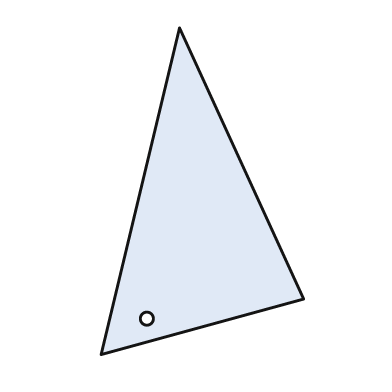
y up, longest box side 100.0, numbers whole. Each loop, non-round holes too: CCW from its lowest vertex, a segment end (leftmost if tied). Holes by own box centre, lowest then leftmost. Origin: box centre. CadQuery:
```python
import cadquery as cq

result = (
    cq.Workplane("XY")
    .moveTo(-31.0, -50.0)
    .lineTo(31.0, -33.0)
    .lineTo(-7.0, 50.0)
    .close()
    .moveTo(-17.0, -39.0)
    .circle(2.0)
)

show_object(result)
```